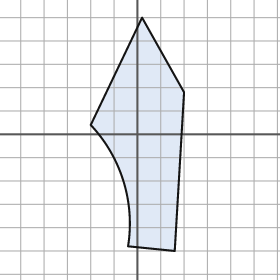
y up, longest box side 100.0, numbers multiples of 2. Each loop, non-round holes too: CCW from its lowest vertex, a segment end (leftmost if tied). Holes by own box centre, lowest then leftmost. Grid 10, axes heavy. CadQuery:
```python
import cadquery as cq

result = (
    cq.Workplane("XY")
    .moveTo(16.0, -50.0)
    .lineTo(20.0, 18.0)
    .lineTo(2.0, 50.0)
    .lineTo(-20.0, 4.0)
    .threePointArc((-6.0, -20.0), (-4.0, -48.0))
    .close()
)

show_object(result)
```